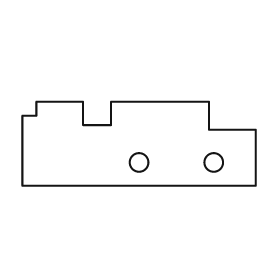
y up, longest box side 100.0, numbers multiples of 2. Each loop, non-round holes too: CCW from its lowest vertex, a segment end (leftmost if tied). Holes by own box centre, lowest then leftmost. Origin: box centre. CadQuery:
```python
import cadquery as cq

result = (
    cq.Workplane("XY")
    .moveTo(-50.0, -18.0)
    .lineTo(50.0, -18.0)
    .lineTo(50.0, 6.0)
    .lineTo(30.0, 6.0)
    .lineTo(30.0, 18.0)
    .lineTo(-12.0, 18.0)
    .lineTo(-12.0, 8.0)
    .lineTo(-24.0, 8.0)
    .lineTo(-24.0, 18.0)
    .lineTo(-44.0, 18.0)
    .lineTo(-44.0, 12.0)
    .lineTo(-50.0, 12.0)
    .close()
    .moveTo(0.0, -8.0)
    .circle(4.0)
    .moveTo(32.0, -8.0)
    .circle(4.0)
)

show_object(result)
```